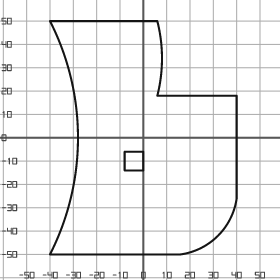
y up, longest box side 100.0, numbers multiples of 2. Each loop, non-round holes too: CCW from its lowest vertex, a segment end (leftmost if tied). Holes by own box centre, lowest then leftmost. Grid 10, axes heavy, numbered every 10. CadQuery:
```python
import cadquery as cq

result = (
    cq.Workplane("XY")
    .moveTo(-40.0, -50.0)
    .lineTo(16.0, -50.0)
    .threePointArc((32.0, -42.0), (40.0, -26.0))
    .lineTo(40.0, 18.0)
    .lineTo(6.0, 18.0)
    .threePointArc((8.0, 34.0), (6.0, 50.0))
    .lineTo(-40.0, 50.0)
    .threePointArc((-28.0, 0.0), (-40.0, -50.0))
    .close()
    .moveTo(-8.0, -14.0)
    .lineTo(0.0, -14.0)
    .lineTo(0.0, -6.0)
    .lineTo(-8.0, -6.0)
    .close()
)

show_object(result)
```